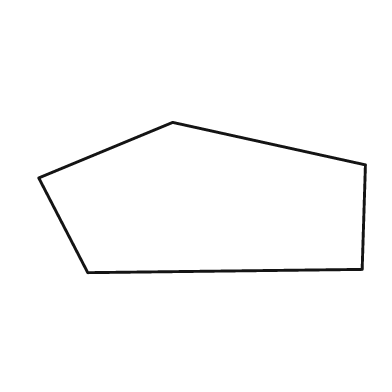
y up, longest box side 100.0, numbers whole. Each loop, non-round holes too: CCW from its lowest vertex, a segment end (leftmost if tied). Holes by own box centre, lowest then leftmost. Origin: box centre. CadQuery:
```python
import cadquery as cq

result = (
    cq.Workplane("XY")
    .moveTo(-35.0, -23.0)
    .lineTo(49.0, -22.0)
    .lineTo(50.0, 10.0)
    .lineTo(-9.0, 23.0)
    .lineTo(-50.0, 6.0)
    .close()
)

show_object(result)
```